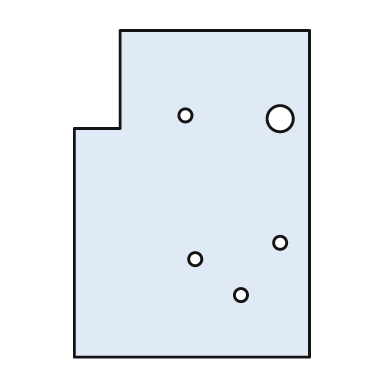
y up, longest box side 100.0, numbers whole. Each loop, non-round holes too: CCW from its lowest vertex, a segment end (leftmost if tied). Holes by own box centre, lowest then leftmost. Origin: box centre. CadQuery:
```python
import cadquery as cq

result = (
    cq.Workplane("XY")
    .moveTo(-36.0, -50.0)
    .lineTo(36.0, -50.0)
    .lineTo(36.0, 50.0)
    .lineTo(-22.0, 50.0)
    .lineTo(-22.0, 20.0)
    .lineTo(-36.0, 20.0)
    .close()
    .moveTo(15.0, -31.0)
    .circle(2.0)
    .moveTo(1.0, -20.0)
    .circle(2.0)
    .moveTo(27.0, -15.0)
    .circle(2.0)
    .moveTo(27.0, 23.0)
    .circle(4.0)
    .moveTo(-2.0, 24.0)
    .circle(2.0)
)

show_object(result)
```